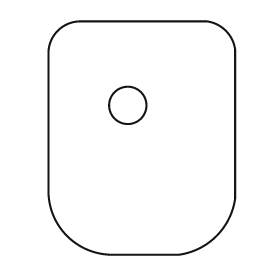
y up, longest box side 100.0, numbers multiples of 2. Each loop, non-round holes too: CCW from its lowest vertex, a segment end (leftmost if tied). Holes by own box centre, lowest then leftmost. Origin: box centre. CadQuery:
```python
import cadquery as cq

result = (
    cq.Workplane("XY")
    .moveTo(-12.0, -50.0)
    .lineTo(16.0, -50.0)
    .threePointArc((32.0, -42.0), (40.0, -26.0))
    .lineTo(40.0, 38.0)
    .threePointArc((36.0, 46.0), (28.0, 50.0))
    .lineTo(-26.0, 50.0)
    .threePointArc((-36.0, 46.0), (-40.0, 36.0))
    .lineTo(-40.0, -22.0)
    .threePointArc((-32.0, -42.0), (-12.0, -50.0))
    .close()
    .moveTo(-6.0, 14.0)
    .circle(8.0)
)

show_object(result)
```